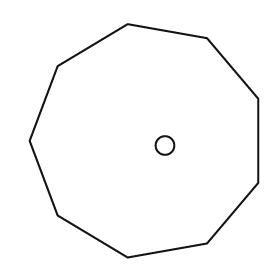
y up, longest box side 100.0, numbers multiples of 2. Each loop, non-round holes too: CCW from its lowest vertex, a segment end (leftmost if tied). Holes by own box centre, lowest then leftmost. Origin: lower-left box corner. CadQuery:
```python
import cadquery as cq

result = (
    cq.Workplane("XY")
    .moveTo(42.0, 0.0)
    .lineTo(76.0, 6.0)
    .lineTo(98.0, 32.0)
    .lineTo(98.0, 68.0)
    .lineTo(76.0, 94.0)
    .lineTo(42.0, 100.0)
    .lineTo(12.0, 82.0)
    .lineTo(0.0, 50.0)
    .lineTo(12.0, 18.0)
    .close()
    .moveTo(58.0, 48.0)
    .circle(4.0)
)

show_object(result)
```